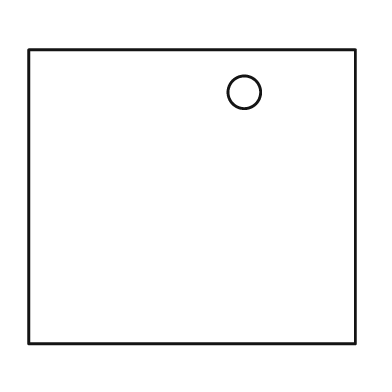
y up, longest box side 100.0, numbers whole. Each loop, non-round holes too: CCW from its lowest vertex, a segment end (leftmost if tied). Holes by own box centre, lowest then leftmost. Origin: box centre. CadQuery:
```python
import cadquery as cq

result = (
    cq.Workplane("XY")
    .moveTo(-50.0, -45.0)
    .lineTo(50.0, -45.0)
    .lineTo(50.0, 45.0)
    .lineTo(-50.0, 45.0)
    .close()
    .moveTo(16.0, 32.0)
    .circle(5.0)
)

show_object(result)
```